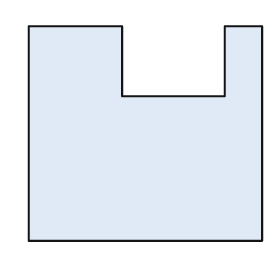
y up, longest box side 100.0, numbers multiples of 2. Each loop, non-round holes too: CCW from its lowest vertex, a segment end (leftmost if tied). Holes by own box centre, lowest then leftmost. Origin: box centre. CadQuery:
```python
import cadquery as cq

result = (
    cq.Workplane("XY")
    .moveTo(-50.0, -46.0)
    .lineTo(50.0, -46.0)
    .lineTo(50.0, 46.0)
    .lineTo(34.0, 46.0)
    .lineTo(34.0, 16.0)
    .lineTo(-10.0, 16.0)
    .lineTo(-10.0, 46.0)
    .lineTo(-50.0, 46.0)
    .close()
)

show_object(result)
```